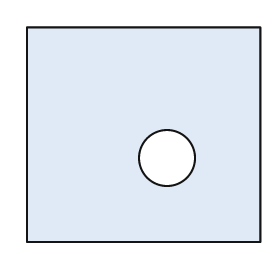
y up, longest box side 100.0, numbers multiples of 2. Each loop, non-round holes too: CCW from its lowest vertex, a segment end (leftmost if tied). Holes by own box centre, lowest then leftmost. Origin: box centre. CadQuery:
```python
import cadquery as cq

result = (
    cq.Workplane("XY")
    .moveTo(-50.0, -46.0)
    .lineTo(50.0, -46.0)
    .lineTo(50.0, 46.0)
    .lineTo(-50.0, 46.0)
    .close()
    .moveTo(10.0, -10.0)
    .circle(12.0)
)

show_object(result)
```